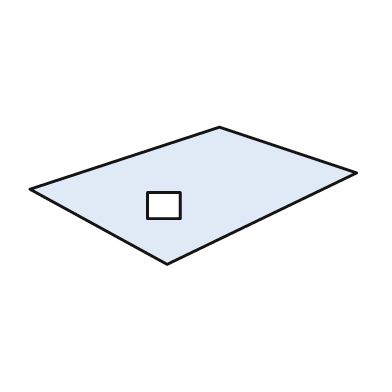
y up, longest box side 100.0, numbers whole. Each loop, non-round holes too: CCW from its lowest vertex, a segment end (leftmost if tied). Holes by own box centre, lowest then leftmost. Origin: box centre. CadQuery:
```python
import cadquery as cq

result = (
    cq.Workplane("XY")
    .moveTo(-8.0, -21.0)
    .lineTo(50.0, 7.0)
    .lineTo(8.0, 21.0)
    .lineTo(-50.0, 2.0)
    .close()
    .moveTo(-14.0, -7.0)
    .lineTo(-4.0, -7.0)
    .lineTo(-4.0, 1.0)
    .lineTo(-14.0, 1.0)
    .close()
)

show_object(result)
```